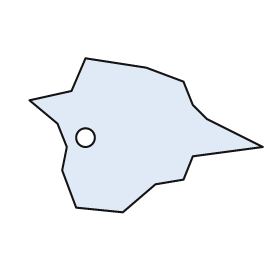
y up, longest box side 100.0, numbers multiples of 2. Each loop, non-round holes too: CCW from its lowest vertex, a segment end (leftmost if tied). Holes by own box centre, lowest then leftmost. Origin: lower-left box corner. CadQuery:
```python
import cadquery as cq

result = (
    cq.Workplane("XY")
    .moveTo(40.0, 0.0)
    .lineTo(54.0, 12.0)
    .lineTo(66.0, 14.0)
    .lineTo(70.0, 24.0)
    .lineTo(100.0, 28.0)
    .lineTo(76.0, 40.0)
    .lineTo(70.0, 46.0)
    .lineTo(66.0, 56.0)
    .lineTo(50.0, 62.0)
    .lineTo(24.0, 66.0)
    .lineTo(18.0, 52.0)
    .lineTo(0.0, 48.0)
    .lineTo(12.0, 38.0)
    .lineTo(16.0, 28.0)
    .lineTo(14.0, 18.0)
    .lineTo(20.0, 2.0)
    .close()
    .moveTo(24.0, 32.0)
    .circle(4.0)
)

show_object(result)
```